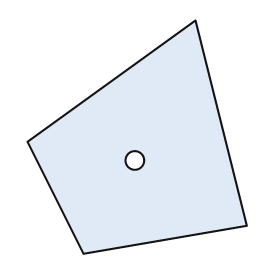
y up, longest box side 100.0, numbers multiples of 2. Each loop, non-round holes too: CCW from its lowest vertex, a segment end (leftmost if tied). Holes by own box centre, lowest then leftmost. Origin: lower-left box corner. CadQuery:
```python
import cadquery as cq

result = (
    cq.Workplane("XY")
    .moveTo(24.0, 0.0)
    .lineTo(94.0, 12.0)
    .lineTo(72.0, 100.0)
    .lineTo(0.0, 48.0)
    .close()
    .moveTo(46.0, 40.0)
    .circle(4.0)
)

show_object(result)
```